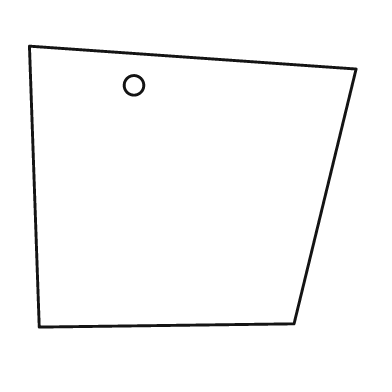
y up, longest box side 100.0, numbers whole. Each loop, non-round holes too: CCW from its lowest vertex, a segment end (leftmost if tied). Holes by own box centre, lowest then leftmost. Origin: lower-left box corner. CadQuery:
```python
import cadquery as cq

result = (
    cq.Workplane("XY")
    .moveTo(3.0, 0.0)
    .lineTo(81.0, 1.0)
    .lineTo(100.0, 79.0)
    .lineTo(0.0, 86.0)
    .close()
    .moveTo(32.0, 74.0)
    .circle(3.0)
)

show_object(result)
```